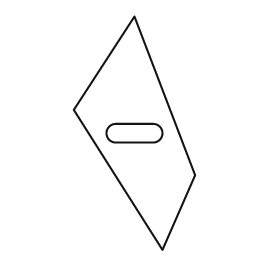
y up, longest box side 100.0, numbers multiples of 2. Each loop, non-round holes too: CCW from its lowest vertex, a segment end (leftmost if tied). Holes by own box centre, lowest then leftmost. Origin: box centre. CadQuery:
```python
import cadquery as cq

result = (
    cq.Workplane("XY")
    .moveTo(12.0, -50.0)
    .lineTo(26.0, -18.0)
    .lineTo(0.0, 50.0)
    .lineTo(-26.0, 10.0)
    .close()
    .moveTo(-8.0, -4.0)
    .lineTo(8.0, -4.0)
    .threePointArc((12.0, 0.0), (8.0, 4.0))
    .lineTo(-8.0, 4.0)
    .threePointArc((-12.0, 0.0), (-8.0, -4.0))
    .close()
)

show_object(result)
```